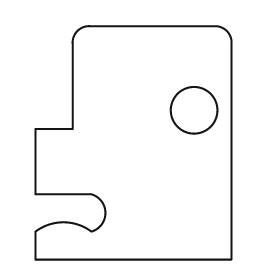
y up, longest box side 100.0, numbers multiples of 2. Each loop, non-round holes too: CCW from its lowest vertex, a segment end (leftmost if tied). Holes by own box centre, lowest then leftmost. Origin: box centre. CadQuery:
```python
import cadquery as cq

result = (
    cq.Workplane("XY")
    .moveTo(-42.0, -50.0)
    .lineTo(42.0, -50.0)
    .lineTo(42.0, 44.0)
    .threePointArc((40.0, 48.0), (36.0, 50.0))
    .lineTo(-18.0, 50.0)
    .threePointArc((-24.0, 48.0), (-26.0, 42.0))
    .lineTo(-26.0, 6.0)
    .lineTo(-42.0, 6.0)
    .lineTo(-42.0, -22.0)
    .lineTo(-18.0, -22.0)
    .threePointArc((-12.0, -30.0), (-18.0, -38.0))
    .threePointArc((-30.0, -34.0), (-42.0, -38.0))
    .close()
    .moveTo(26.0, 14.0)
    .circle(10.0)
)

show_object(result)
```